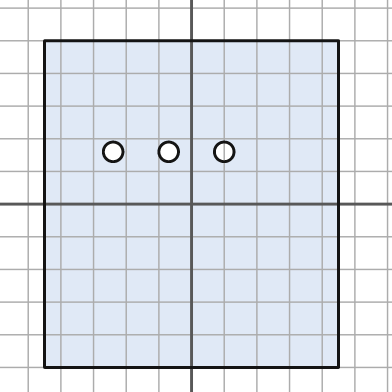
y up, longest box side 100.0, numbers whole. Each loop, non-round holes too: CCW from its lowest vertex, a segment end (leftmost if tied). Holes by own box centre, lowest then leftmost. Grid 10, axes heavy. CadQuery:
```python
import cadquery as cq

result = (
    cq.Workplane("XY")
    .moveTo(-45.0, -50.0)
    .lineTo(45.0, -50.0)
    .lineTo(45.0, 50.0)
    .lineTo(-45.0, 50.0)
    .close()
    .moveTo(-24.0, 16.0)
    .circle(3.0)
    .moveTo(-7.0, 16.0)
    .circle(3.0)
    .moveTo(10.0, 16.0)
    .circle(3.0)
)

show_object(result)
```